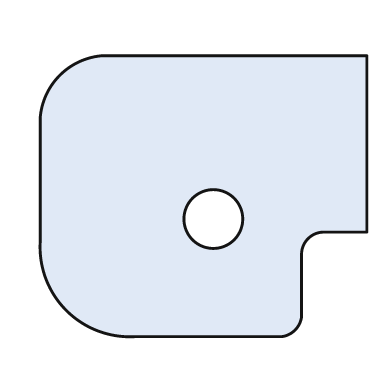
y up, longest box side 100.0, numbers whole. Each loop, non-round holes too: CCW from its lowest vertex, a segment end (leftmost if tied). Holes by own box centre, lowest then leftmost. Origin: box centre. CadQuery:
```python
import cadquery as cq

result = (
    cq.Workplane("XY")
    .moveTo(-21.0, -43.0)
    .lineTo(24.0, -43.0)
    .threePointArc((28.0, -41.0), (30.0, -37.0))
    .lineTo(30.0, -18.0)
    .threePointArc((32.0, -13.0), (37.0, -11.0))
    .lineTo(50.0, -11.0)
    .lineTo(50.0, 43.0)
    .lineTo(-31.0, 43.0)
    .threePointArc((-44.0, 37.0), (-50.0, 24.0))
    .lineTo(-50.0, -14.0)
    .threePointArc((-42.0, -35.0), (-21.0, -43.0))
    .close()
    .moveTo(3.0, -7.0)
    .circle(9.0)
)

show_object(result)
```